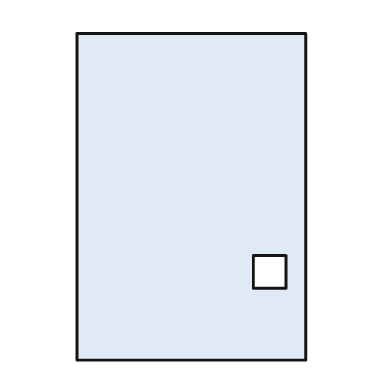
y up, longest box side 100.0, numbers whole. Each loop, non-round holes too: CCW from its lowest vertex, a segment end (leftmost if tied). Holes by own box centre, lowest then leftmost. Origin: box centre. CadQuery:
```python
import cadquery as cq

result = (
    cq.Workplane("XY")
    .moveTo(-35.0, -50.0)
    .lineTo(35.0, -50.0)
    .lineTo(35.0, 50.0)
    .lineTo(-35.0, 50.0)
    .close()
    .moveTo(19.0, -28.0)
    .lineTo(29.0, -28.0)
    .lineTo(29.0, -18.0)
    .lineTo(19.0, -18.0)
    .close()
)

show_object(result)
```